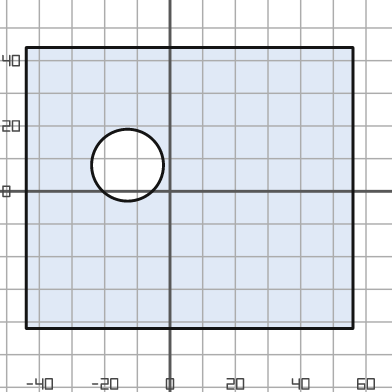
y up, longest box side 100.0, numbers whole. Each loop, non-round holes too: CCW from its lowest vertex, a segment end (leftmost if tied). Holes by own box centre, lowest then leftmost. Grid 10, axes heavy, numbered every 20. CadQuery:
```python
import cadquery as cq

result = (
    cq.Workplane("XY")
    .moveTo(-44.0, -42.0)
    .lineTo(56.0, -42.0)
    .lineTo(56.0, 44.0)
    .lineTo(-44.0, 44.0)
    .close()
    .moveTo(-13.0, 8.0)
    .circle(11.0)
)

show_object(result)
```